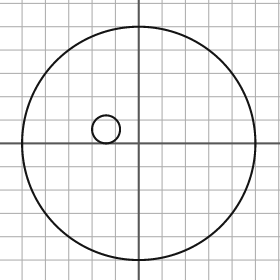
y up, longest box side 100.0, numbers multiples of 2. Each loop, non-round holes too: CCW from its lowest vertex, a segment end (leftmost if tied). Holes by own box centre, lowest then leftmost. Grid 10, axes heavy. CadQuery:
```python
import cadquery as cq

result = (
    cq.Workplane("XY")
    .moveTo(0.0, 0.0)
    .circle(50.0)
    .moveTo(-14.0, 6.0)
    .circle(6.0)
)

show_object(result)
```